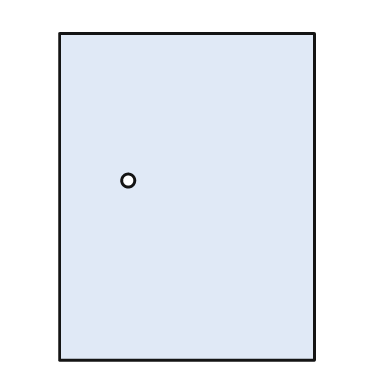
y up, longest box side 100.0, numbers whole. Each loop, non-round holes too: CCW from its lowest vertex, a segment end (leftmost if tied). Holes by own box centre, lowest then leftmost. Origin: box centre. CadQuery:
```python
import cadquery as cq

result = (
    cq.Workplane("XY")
    .moveTo(-39.0, -50.0)
    .lineTo(39.0, -50.0)
    .lineTo(39.0, 50.0)
    .lineTo(-39.0, 50.0)
    .close()
    .moveTo(-18.0, 5.0)
    .circle(2.0)
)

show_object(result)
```